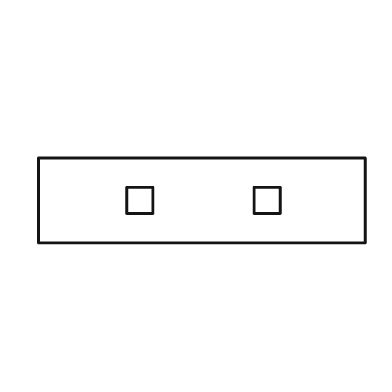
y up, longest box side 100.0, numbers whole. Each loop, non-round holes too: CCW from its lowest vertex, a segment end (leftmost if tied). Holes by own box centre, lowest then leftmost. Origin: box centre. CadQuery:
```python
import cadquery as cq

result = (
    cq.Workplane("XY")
    .moveTo(-50.0, -13.0)
    .lineTo(50.0, -13.0)
    .lineTo(50.0, 13.0)
    .lineTo(-50.0, 13.0)
    .close()
    .moveTo(-23.0, -4.0)
    .lineTo(-15.0, -4.0)
    .lineTo(-15.0, 4.0)
    .lineTo(-23.0, 4.0)
    .close()
    .moveTo(16.0, -4.0)
    .lineTo(24.0, -4.0)
    .lineTo(24.0, 4.0)
    .lineTo(16.0, 4.0)
    .close()
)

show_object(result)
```